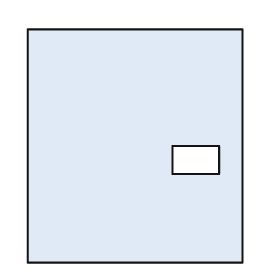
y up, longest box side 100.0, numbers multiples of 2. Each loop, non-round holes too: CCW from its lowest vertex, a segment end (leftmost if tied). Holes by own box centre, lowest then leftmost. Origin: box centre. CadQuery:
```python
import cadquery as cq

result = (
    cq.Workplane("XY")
    .moveTo(-46.0, -50.0)
    .lineTo(46.0, -50.0)
    .lineTo(46.0, 50.0)
    .lineTo(-46.0, 50.0)
    .close()
    .moveTo(16.0, -12.0)
    .lineTo(36.0, -12.0)
    .lineTo(36.0, 0.0)
    .lineTo(16.0, 0.0)
    .close()
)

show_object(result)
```